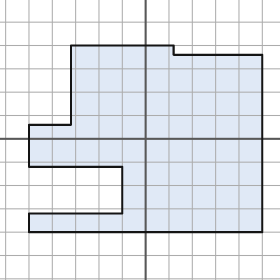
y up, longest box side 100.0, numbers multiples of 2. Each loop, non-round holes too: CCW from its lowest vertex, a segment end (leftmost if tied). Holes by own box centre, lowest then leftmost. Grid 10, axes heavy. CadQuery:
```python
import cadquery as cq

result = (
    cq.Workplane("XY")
    .moveTo(-50.0, -40.0)
    .lineTo(50.0, -40.0)
    .lineTo(50.0, 36.0)
    .lineTo(12.0, 36.0)
    .lineTo(12.0, 40.0)
    .lineTo(-32.0, 40.0)
    .lineTo(-32.0, 6.0)
    .lineTo(-50.0, 6.0)
    .lineTo(-50.0, -12.0)
    .lineTo(-10.0, -12.0)
    .lineTo(-10.0, -32.0)
    .lineTo(-50.0, -32.0)
    .close()
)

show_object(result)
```